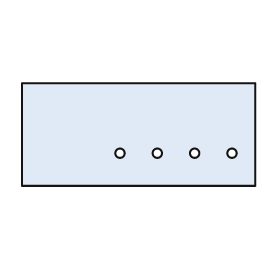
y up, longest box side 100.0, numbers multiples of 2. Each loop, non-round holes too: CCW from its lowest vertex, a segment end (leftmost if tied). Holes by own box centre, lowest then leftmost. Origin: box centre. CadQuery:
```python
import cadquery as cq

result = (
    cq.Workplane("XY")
    .moveTo(-50.0, -22.0)
    .lineTo(50.0, -22.0)
    .lineTo(50.0, 22.0)
    .lineTo(-50.0, 22.0)
    .close()
    .moveTo(-8.0, -8.0)
    .circle(2.0)
    .moveTo(8.0, -8.0)
    .circle(2.0)
    .moveTo(24.0, -8.0)
    .circle(2.0)
    .moveTo(40.0, -8.0)
    .circle(2.0)
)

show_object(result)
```